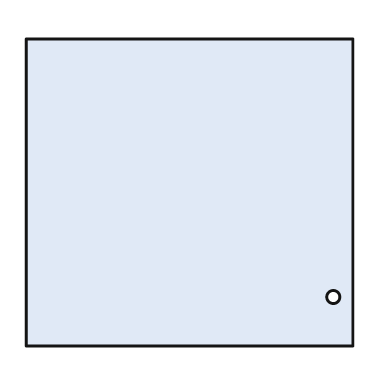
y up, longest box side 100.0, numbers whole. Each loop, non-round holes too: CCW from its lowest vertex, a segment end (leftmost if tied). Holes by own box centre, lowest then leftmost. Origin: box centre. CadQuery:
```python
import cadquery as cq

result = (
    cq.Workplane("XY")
    .moveTo(-50.0, -47.0)
    .lineTo(50.0, -47.0)
    .lineTo(50.0, 47.0)
    .lineTo(-50.0, 47.0)
    .close()
    .moveTo(44.0, -32.0)
    .circle(2.0)
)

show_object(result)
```